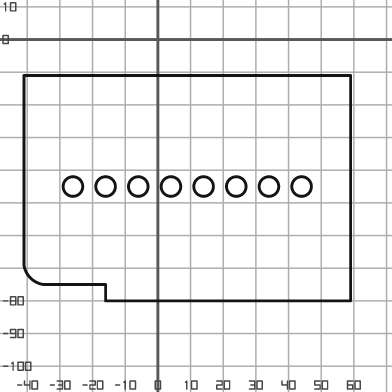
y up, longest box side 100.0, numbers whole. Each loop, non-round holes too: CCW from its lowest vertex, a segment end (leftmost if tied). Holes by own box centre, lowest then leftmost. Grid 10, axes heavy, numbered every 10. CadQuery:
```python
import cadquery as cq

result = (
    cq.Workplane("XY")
    .moveTo(-16.0, -80.0)
    .lineTo(59.0, -80.0)
    .lineTo(59.0, -11.0)
    .lineTo(-41.0, -11.0)
    .lineTo(-41.0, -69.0)
    .threePointArc((-39.0, -73.0), (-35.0, -75.0))
    .lineTo(-16.0, -75.0)
    .close()
    .moveTo(-26.0, -45.0)
    .circle(3.0)
    .moveTo(-16.0, -45.0)
    .circle(3.0)
    .moveTo(-6.0, -45.0)
    .circle(3.0)
    .moveTo(4.0, -45.0)
    .circle(3.0)
    .moveTo(14.0, -45.0)
    .circle(3.0)
    .moveTo(24.0, -45.0)
    .circle(3.0)
    .moveTo(34.0, -45.0)
    .circle(3.0)
    .moveTo(44.0, -45.0)
    .circle(3.0)
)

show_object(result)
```